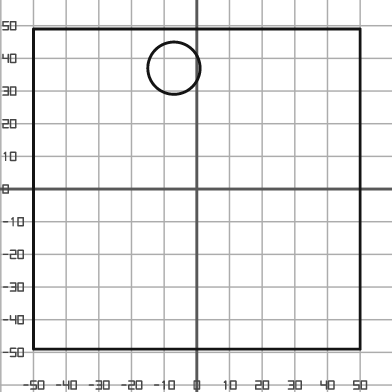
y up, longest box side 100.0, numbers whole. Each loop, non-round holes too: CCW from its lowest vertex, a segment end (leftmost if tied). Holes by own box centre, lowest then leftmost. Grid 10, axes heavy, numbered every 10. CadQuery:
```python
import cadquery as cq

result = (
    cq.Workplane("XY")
    .moveTo(-50.0, -49.0)
    .lineTo(50.0, -49.0)
    .lineTo(50.0, 49.0)
    .lineTo(-50.0, 49.0)
    .close()
    .moveTo(-7.0, 37.0)
    .circle(8.0)
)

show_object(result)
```